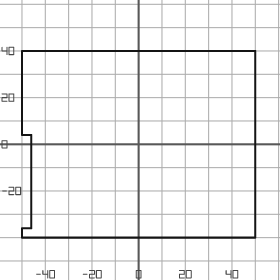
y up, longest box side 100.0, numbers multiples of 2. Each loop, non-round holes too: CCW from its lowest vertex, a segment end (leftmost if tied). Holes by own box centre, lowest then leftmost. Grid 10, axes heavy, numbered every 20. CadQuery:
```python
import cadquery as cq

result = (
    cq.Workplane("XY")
    .moveTo(-50.0, -40.0)
    .lineTo(50.0, -40.0)
    .lineTo(50.0, 40.0)
    .lineTo(-50.0, 40.0)
    .lineTo(-50.0, 4.0)
    .lineTo(-46.0, 4.0)
    .lineTo(-46.0, -36.0)
    .lineTo(-50.0, -36.0)
    .close()
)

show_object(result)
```